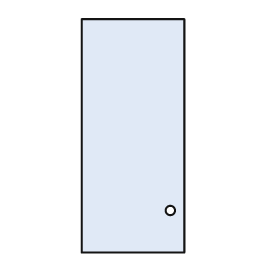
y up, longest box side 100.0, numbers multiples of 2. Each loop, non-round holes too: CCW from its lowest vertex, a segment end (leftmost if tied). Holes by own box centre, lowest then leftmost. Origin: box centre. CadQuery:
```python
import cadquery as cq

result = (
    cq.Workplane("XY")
    .moveTo(-22.0, -50.0)
    .lineTo(22.0, -50.0)
    .lineTo(22.0, 50.0)
    .lineTo(-22.0, 50.0)
    .close()
    .moveTo(16.0, -32.0)
    .circle(2.0)
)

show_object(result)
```